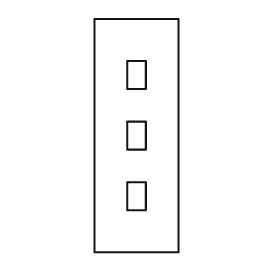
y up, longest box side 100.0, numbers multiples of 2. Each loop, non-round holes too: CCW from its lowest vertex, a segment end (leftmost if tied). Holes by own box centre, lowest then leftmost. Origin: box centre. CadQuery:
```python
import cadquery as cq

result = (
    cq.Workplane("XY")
    .moveTo(-18.0, -50.0)
    .lineTo(18.0, -50.0)
    .lineTo(18.0, 50.0)
    .lineTo(-18.0, 50.0)
    .close()
    .moveTo(-4.0, -32.0)
    .lineTo(4.0, -32.0)
    .lineTo(4.0, -20.0)
    .lineTo(-4.0, -20.0)
    .close()
    .moveTo(-4.0, -6.0)
    .lineTo(4.0, -6.0)
    .lineTo(4.0, 6.0)
    .lineTo(-4.0, 6.0)
    .close()
    .moveTo(-4.0, 20.0)
    .lineTo(4.0, 20.0)
    .lineTo(4.0, 32.0)
    .lineTo(-4.0, 32.0)
    .close()
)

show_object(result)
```